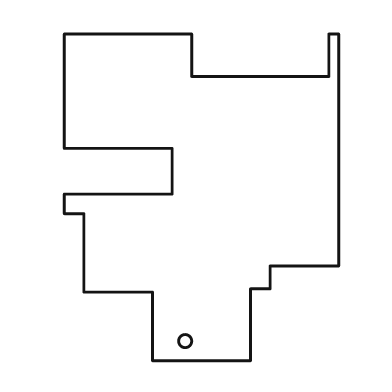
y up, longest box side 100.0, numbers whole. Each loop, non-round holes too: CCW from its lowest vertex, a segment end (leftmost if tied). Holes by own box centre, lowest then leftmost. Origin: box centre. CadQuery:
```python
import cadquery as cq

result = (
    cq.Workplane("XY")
    .moveTo(-15.0, -50.0)
    .lineTo(15.0, -50.0)
    .lineTo(15.0, -28.0)
    .lineTo(21.0, -28.0)
    .lineTo(21.0, -21.0)
    .lineTo(42.0, -21.0)
    .lineTo(42.0, 50.0)
    .lineTo(39.0, 50.0)
    .lineTo(39.0, 37.0)
    .lineTo(-3.0, 37.0)
    .lineTo(-3.0, 50.0)
    .lineTo(-42.0, 50.0)
    .lineTo(-42.0, 15.0)
    .lineTo(-9.0, 15.0)
    .lineTo(-9.0, 1.0)
    .lineTo(-42.0, 1.0)
    .lineTo(-42.0, -5.0)
    .lineTo(-36.0, -5.0)
    .lineTo(-36.0, -29.0)
    .lineTo(-15.0, -29.0)
    .close()
    .moveTo(-5.0, -44.0)
    .circle(2.0)
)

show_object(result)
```